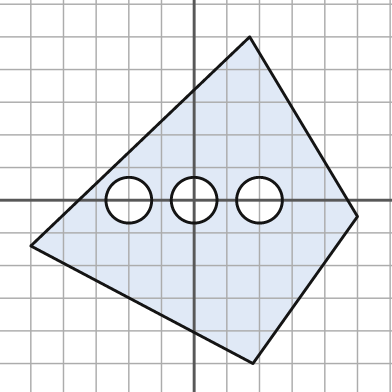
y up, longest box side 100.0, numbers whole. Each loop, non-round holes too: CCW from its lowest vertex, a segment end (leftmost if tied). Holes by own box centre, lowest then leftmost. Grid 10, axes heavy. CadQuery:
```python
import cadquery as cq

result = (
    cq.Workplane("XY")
    .moveTo(18.0, -50.0)
    .lineTo(50.0, -5.0)
    .lineTo(17.0, 50.0)
    .lineTo(-50.0, -14.0)
    .close()
    .moveTo(-20.0, 0.0)
    .circle(7.0)
    .moveTo(0.0, 0.0)
    .circle(7.0)
    .moveTo(20.0, 0.0)
    .circle(7.0)
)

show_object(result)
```